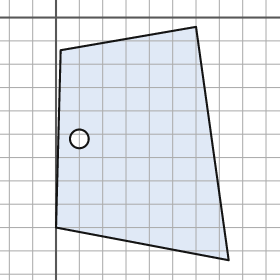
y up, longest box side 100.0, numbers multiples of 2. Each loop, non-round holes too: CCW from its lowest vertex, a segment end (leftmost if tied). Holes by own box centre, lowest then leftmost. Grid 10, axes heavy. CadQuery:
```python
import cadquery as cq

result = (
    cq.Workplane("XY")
    .moveTo(74.0, -104.0)
    .lineTo(60.0, -4.0)
    .lineTo(2.0, -14.0)
    .lineTo(0.0, -90.0)
    .close()
    .moveTo(10.0, -52.0)
    .circle(4.0)
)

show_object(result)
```